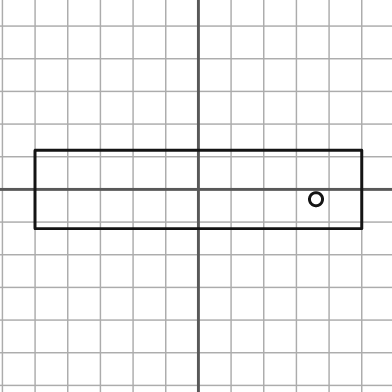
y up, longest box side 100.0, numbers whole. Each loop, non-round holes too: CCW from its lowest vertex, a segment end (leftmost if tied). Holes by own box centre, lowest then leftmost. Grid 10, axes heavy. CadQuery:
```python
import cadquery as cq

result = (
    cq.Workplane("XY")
    .moveTo(-50.0, -12.0)
    .lineTo(50.0, -12.0)
    .lineTo(50.0, 12.0)
    .lineTo(-50.0, 12.0)
    .close()
    .moveTo(36.0, -3.0)
    .circle(2.0)
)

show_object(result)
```